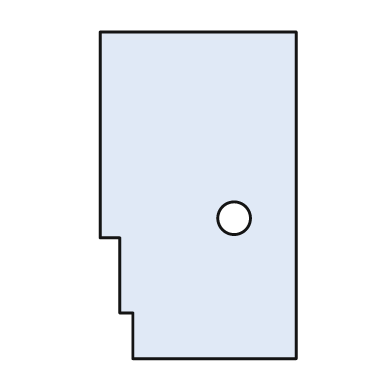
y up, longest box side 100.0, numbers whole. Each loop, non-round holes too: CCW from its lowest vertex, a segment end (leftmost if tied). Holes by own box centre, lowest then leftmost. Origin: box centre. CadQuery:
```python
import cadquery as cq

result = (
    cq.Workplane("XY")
    .moveTo(-20.0, -50.0)
    .lineTo(30.0, -50.0)
    .lineTo(30.0, 50.0)
    .lineTo(-30.0, 50.0)
    .lineTo(-30.0, -13.0)
    .lineTo(-24.0, -13.0)
    .lineTo(-24.0, -36.0)
    .lineTo(-20.0, -36.0)
    .close()
    .moveTo(11.0, -7.0)
    .circle(5.0)
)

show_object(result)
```